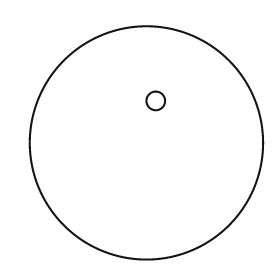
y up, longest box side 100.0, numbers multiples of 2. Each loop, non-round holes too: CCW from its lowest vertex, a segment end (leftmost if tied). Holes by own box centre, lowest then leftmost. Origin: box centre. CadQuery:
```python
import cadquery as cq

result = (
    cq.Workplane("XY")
    .moveTo(0.0, 0.0)
    .circle(50.0)
    .moveTo(4.0, 18.0)
    .circle(4.0)
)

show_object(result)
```